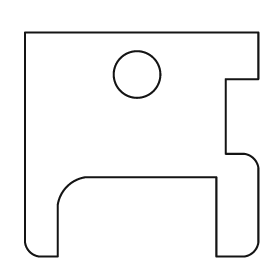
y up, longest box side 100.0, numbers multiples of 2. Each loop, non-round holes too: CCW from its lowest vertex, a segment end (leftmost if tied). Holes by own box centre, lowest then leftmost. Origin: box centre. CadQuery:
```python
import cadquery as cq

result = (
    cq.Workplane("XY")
    .moveTo(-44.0, -48.0)
    .lineTo(-36.0, -48.0)
    .lineTo(-36.0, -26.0)
    .threePointArc((-32.0, -18.0), (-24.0, -14.0))
    .lineTo(32.0, -14.0)
    .lineTo(32.0, -48.0)
    .lineTo(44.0, -48.0)
    .threePointArc((48.0, -46.0), (50.0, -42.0))
    .lineTo(50.0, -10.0)
    .threePointArc((48.0, -6.0), (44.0, -4.0))
    .lineTo(36.0, -4.0)
    .lineTo(36.0, 28.0)
    .lineTo(50.0, 28.0)
    .lineTo(50.0, 48.0)
    .lineTo(-50.0, 48.0)
    .lineTo(-50.0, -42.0)
    .threePointArc((-48.0, -46.0), (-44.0, -48.0))
    .close()
    .moveTo(-2.0, 30.0)
    .circle(10.0)
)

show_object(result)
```